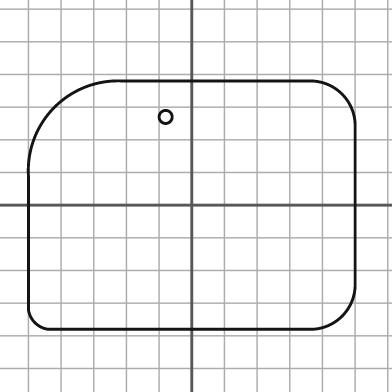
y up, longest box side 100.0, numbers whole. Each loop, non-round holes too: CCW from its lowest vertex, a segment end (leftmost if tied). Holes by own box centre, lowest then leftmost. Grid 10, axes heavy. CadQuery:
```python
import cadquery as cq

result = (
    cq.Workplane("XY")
    .moveTo(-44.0, -38.0)
    .lineTo(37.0, -38.0)
    .threePointArc((46.0, -34.0), (50.0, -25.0))
    .lineTo(50.0, 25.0)
    .threePointArc((46.0, 34.0), (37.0, 38.0))
    .lineTo(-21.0, 38.0)
    .threePointArc((-42.0, 30.0), (-50.0, 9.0))
    .lineTo(-50.0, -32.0)
    .threePointArc((-48.0, -36.0), (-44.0, -38.0))
    .close()
    .moveTo(-8.0, 27.0)
    .circle(2.0)
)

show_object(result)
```